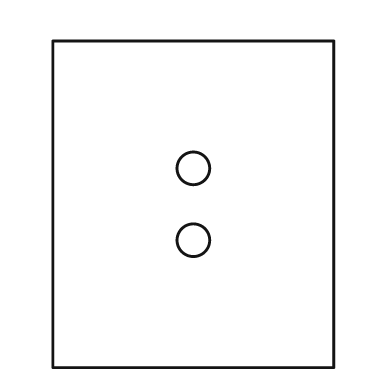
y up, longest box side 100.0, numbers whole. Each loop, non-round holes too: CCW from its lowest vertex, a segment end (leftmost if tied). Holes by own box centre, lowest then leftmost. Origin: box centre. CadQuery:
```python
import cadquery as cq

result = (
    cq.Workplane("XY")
    .moveTo(-43.0, -50.0)
    .lineTo(43.0, -50.0)
    .lineTo(43.0, 50.0)
    .lineTo(-43.0, 50.0)
    .close()
    .moveTo(0.0, -11.0)
    .circle(5.0)
    .moveTo(0.0, 11.0)
    .circle(5.0)
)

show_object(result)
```